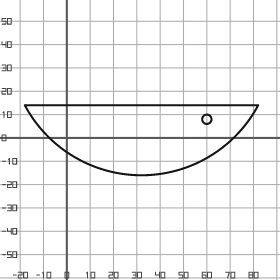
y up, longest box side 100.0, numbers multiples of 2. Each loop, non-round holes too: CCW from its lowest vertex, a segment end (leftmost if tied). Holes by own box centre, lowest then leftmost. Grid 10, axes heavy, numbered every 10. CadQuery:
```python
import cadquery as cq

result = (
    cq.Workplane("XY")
    .moveTo(-18.0, 14.0)
    .threePointArc((32.0, -16.0), (82.0, 14.0))
    .close()
    .moveTo(60.0, 8.0)
    .circle(2.0)
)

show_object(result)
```